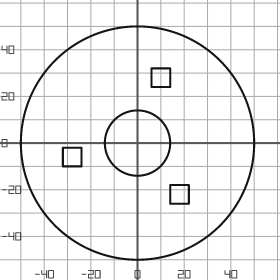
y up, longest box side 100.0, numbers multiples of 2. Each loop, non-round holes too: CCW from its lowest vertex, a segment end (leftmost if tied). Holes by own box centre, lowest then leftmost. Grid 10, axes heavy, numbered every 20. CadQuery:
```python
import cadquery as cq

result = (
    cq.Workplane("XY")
    .moveTo(0.0, 0.0)
    .circle(50.0)
    .moveTo(14.0, -26.0)
    .lineTo(22.0, -26.0)
    .lineTo(22.0, -18.0)
    .lineTo(14.0, -18.0)
    .close()
    .moveTo(-32.0, -10.0)
    .lineTo(-24.0, -10.0)
    .lineTo(-24.0, -2.0)
    .lineTo(-32.0, -2.0)
    .close()
    .moveTo(0.0, 0.0)
    .circle(14.0)
    .moveTo(6.0, 24.0)
    .lineTo(14.0, 24.0)
    .lineTo(14.0, 32.0)
    .lineTo(6.0, 32.0)
    .close()
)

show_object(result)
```